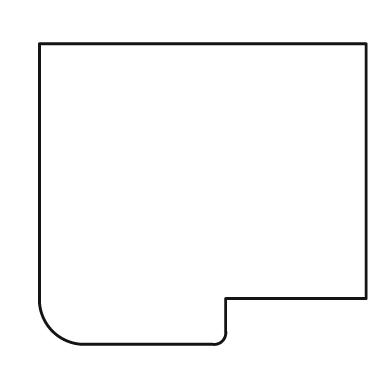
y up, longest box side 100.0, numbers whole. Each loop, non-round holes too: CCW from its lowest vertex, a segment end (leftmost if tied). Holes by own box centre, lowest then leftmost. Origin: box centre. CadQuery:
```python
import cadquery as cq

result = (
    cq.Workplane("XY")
    .moveTo(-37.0, -46.0)
    .lineTo(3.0, -46.0)
    .threePointArc((6.0, -45.0), (7.0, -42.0))
    .lineTo(7.0, -32.0)
    .lineTo(50.0, -32.0)
    .lineTo(50.0, 46.0)
    .lineTo(-50.0, 46.0)
    .lineTo(-50.0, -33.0)
    .threePointArc((-46.0, -42.0), (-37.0, -46.0))
    .close()
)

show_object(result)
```